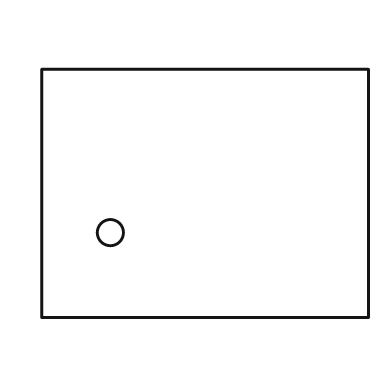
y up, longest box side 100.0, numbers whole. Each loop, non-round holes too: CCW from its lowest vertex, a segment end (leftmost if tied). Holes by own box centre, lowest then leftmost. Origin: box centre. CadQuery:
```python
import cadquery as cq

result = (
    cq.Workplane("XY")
    .moveTo(-50.0, -38.0)
    .lineTo(50.0, -38.0)
    .lineTo(50.0, 38.0)
    .lineTo(-50.0, 38.0)
    .close()
    .moveTo(-29.0, -12.0)
    .circle(4.0)
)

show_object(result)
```